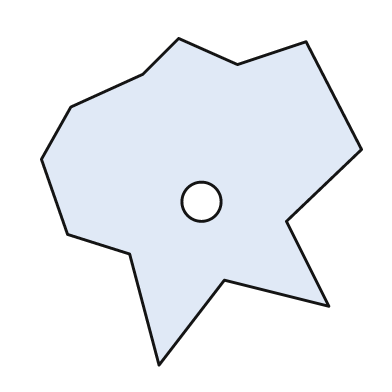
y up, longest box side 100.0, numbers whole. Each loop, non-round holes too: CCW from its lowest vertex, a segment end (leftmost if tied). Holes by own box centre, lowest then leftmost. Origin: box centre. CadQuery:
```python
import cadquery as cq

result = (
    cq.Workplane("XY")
    .moveTo(-13.0, -50.0)
    .lineTo(7.0, -24.0)
    .lineTo(39.0, -32.0)
    .lineTo(26.0, -6.0)
    .lineTo(49.0, 16.0)
    .lineTo(32.0, 49.0)
    .lineTo(11.0, 42.0)
    .lineTo(-7.0, 50.0)
    .lineTo(-18.0, 39.0)
    .lineTo(-40.0, 29.0)
    .lineTo(-49.0, 13.0)
    .lineTo(-41.0, -10.0)
    .lineTo(-22.0, -16.0)
    .close()
    .moveTo(0.0, 0.0)
    .circle(6.0)
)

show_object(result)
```